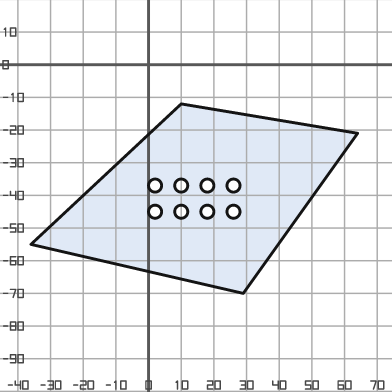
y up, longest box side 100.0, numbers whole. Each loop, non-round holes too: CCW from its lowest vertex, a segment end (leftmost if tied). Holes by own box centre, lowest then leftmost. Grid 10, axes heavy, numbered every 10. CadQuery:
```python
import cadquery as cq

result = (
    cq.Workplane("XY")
    .moveTo(29.0, -70.0)
    .lineTo(64.0, -21.0)
    .lineTo(10.0, -12.0)
    .lineTo(-36.0, -55.0)
    .close()
    .moveTo(2.0, -45.0)
    .circle(2.0)
    .moveTo(10.0, -45.0)
    .circle(2.0)
    .moveTo(18.0, -45.0)
    .circle(2.0)
    .moveTo(26.0, -45.0)
    .circle(2.0)
    .moveTo(2.0, -37.0)
    .circle(2.0)
    .moveTo(10.0, -37.0)
    .circle(2.0)
    .moveTo(18.0, -37.0)
    .circle(2.0)
    .moveTo(26.0, -37.0)
    .circle(2.0)
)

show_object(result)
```